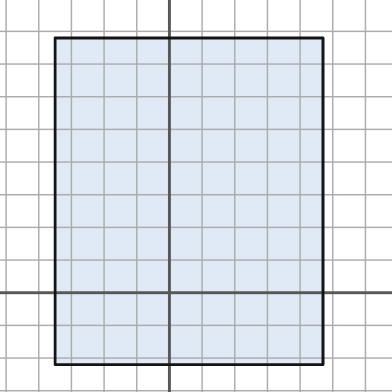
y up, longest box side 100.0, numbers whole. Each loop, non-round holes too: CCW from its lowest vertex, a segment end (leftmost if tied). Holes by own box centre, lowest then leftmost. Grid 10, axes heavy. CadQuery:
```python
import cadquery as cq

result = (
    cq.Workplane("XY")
    .moveTo(-35.0, -22.0)
    .lineTo(47.0, -22.0)
    .lineTo(47.0, 78.0)
    .lineTo(-35.0, 78.0)
    .close()
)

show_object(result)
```